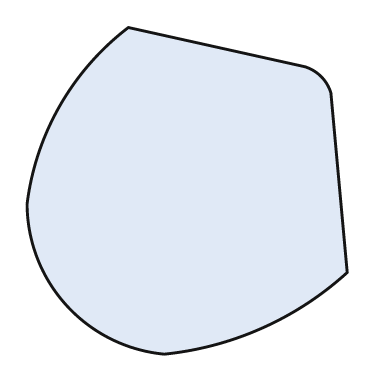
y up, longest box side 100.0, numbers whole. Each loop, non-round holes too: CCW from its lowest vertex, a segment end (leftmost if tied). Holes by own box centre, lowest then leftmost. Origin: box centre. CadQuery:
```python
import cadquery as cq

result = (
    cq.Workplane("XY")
    .moveTo(-7.0, -50.0)
    .threePointArc((23.0, -42.0), (49.0, -25.0))
    .lineTo(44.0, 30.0)
    .threePointArc((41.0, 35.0), (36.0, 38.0))
    .lineTo(-18.0, 50.0)
    .threePointArc((-39.0, 26.0), (-49.0, -4.0))
    .threePointArc((-37.0, -35.0), (-7.0, -50.0))
    .close()
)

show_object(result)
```